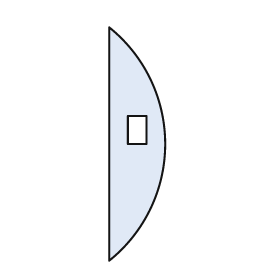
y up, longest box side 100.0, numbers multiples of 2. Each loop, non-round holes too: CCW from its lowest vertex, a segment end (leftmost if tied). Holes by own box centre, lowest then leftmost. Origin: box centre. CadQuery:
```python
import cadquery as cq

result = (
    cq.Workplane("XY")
    .moveTo(-12.0, -50.0)
    .threePointArc((12.0, 0.0), (-12.0, 50.0))
    .close()
    .moveTo(-4.0, 0.0)
    .lineTo(4.0, 0.0)
    .lineTo(4.0, 12.0)
    .lineTo(-4.0, 12.0)
    .close()
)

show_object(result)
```